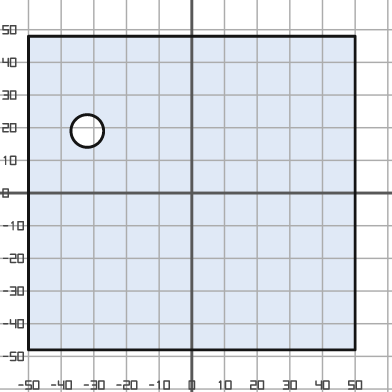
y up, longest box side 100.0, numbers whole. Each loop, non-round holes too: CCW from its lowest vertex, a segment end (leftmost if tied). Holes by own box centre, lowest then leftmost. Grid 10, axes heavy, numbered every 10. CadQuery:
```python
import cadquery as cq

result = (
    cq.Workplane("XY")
    .moveTo(-50.0, -48.0)
    .lineTo(50.0, -48.0)
    .lineTo(50.0, 48.0)
    .lineTo(-50.0, 48.0)
    .close()
    .moveTo(-32.0, 19.0)
    .circle(5.0)
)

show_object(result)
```